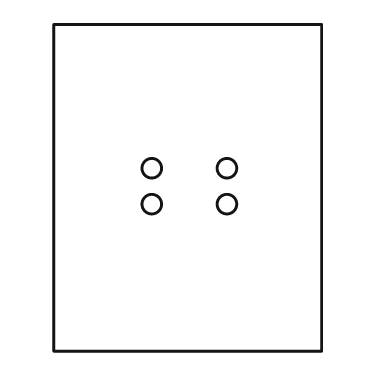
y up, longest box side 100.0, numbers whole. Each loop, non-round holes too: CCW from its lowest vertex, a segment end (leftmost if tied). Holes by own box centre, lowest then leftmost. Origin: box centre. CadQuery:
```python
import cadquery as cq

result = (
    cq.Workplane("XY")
    .moveTo(-41.0, -50.0)
    .lineTo(41.0, -50.0)
    .lineTo(41.0, 50.0)
    .lineTo(-41.0, 50.0)
    .close()
    .moveTo(-11.0, -5.0)
    .circle(3.0)
    .moveTo(12.0, -5.0)
    .circle(3.0)
    .moveTo(-11.0, 6.0)
    .circle(3.0)
    .moveTo(12.0, 6.0)
    .circle(3.0)
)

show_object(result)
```